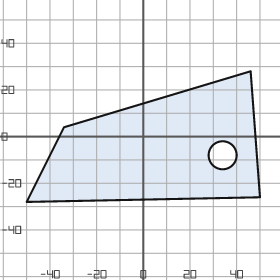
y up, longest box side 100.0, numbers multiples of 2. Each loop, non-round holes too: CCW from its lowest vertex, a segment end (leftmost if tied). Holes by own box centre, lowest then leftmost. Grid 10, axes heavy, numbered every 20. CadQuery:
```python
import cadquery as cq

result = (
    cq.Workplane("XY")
    .moveTo(-50.0, -28.0)
    .lineTo(50.0, -26.0)
    .lineTo(46.0, 28.0)
    .lineTo(-34.0, 4.0)
    .close()
    .moveTo(34.0, -8.0)
    .circle(6.0)
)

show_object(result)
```